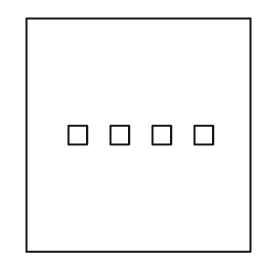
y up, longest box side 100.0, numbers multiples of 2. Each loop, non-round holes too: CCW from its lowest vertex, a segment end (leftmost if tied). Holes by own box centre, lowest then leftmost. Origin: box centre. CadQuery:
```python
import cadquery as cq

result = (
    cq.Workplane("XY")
    .moveTo(-48.0, -50.0)
    .lineTo(48.0, -50.0)
    .lineTo(48.0, 50.0)
    .lineTo(-48.0, 50.0)
    .close()
    .moveTo(-30.0, -4.0)
    .lineTo(-22.0, -4.0)
    .lineTo(-22.0, 4.0)
    .lineTo(-30.0, 4.0)
    .close()
    .moveTo(-12.0, -4.0)
    .lineTo(-4.0, -4.0)
    .lineTo(-4.0, 4.0)
    .lineTo(-12.0, 4.0)
    .close()
    .moveTo(6.0, -4.0)
    .lineTo(14.0, -4.0)
    .lineTo(14.0, 4.0)
    .lineTo(6.0, 4.0)
    .close()
    .moveTo(24.0, -4.0)
    .lineTo(32.0, -4.0)
    .lineTo(32.0, 4.0)
    .lineTo(24.0, 4.0)
    .close()
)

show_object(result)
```